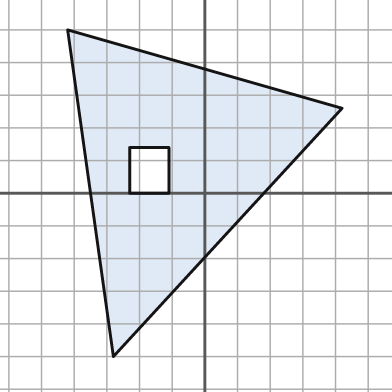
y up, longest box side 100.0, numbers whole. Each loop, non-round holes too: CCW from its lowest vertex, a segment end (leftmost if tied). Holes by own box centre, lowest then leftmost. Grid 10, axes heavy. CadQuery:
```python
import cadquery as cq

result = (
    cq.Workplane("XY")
    .moveTo(-28.0, -50.0)
    .lineTo(42.0, 26.0)
    .lineTo(-42.0, 50.0)
    .close()
    .moveTo(-23.0, 0.0)
    .lineTo(-11.0, 0.0)
    .lineTo(-11.0, 14.0)
    .lineTo(-23.0, 14.0)
    .close()
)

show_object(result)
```